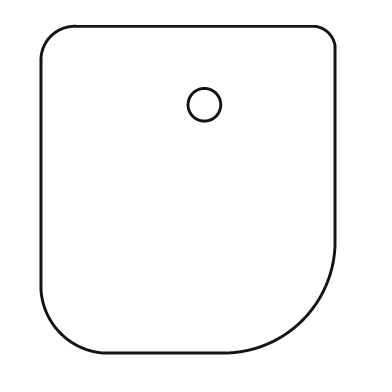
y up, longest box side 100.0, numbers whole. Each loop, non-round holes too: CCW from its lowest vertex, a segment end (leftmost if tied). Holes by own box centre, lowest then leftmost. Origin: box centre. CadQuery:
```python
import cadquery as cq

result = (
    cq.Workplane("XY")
    .moveTo(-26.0, -50.0)
    .lineTo(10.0, -50.0)
    .threePointArc((35.0, -40.0), (45.0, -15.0))
    .lineTo(45.0, 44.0)
    .threePointArc((43.0, 48.0), (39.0, 50.0))
    .lineTo(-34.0, 50.0)
    .threePointArc((-42.0, 47.0), (-45.0, 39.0))
    .lineTo(-45.0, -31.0)
    .threePointArc((-39.0, -44.0), (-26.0, -50.0))
    .close()
    .moveTo(5.0, 26.0)
    .circle(5.0)
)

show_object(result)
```